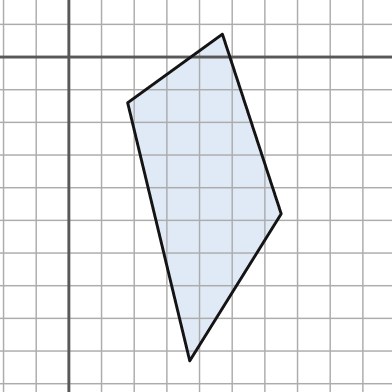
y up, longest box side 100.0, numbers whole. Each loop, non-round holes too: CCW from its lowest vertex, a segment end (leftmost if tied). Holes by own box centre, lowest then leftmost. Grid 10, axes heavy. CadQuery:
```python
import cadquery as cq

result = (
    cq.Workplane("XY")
    .moveTo(37.0, -93.0)
    .lineTo(65.0, -48.0)
    .lineTo(47.0, 7.0)
    .lineTo(18.0, -14.0)
    .close()
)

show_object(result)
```